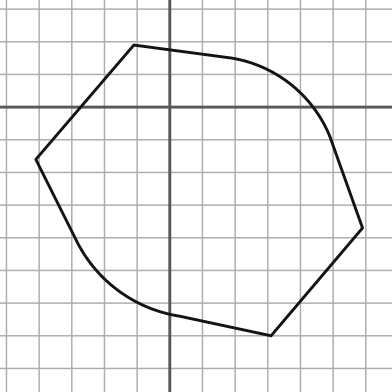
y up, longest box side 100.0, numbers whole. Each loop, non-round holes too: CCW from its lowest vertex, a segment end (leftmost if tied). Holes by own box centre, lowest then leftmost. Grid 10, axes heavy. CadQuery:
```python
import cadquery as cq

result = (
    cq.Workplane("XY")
    .moveTo(31.0, -70.0)
    .lineTo(59.0, -37.0)
    .lineTo(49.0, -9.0)
    .threePointArc((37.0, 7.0), (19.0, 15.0))
    .lineTo(-11.0, 19.0)
    .lineTo(-41.0, -16.0)
    .lineTo(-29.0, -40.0)
    .threePointArc((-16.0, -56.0), (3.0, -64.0))
    .close()
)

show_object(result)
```